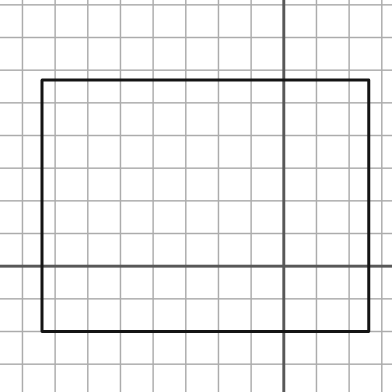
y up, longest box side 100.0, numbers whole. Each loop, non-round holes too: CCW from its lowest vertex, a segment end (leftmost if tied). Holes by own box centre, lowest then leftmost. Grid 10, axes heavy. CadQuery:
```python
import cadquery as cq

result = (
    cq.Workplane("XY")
    .moveTo(-74.0, -20.0)
    .lineTo(26.0, -20.0)
    .lineTo(26.0, 57.0)
    .lineTo(-74.0, 57.0)
    .close()
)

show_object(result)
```